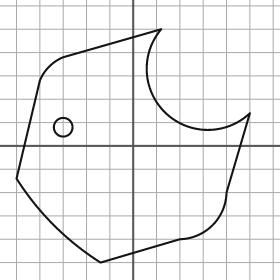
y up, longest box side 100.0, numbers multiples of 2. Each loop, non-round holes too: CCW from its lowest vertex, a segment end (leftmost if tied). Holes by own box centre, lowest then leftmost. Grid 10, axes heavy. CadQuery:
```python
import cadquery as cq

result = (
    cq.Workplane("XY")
    .moveTo(-14.0, -50.0)
    .lineTo(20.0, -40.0)
    .threePointArc((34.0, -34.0), (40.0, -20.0))
    .lineTo(50.0, 14.0)
    .threePointArc((14.0, 14.0), (12.0, 50.0))
    .lineTo(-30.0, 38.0)
    .threePointArc((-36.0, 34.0), (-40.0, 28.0))
    .lineTo(-50.0, -14.0)
    .threePointArc((-34.0, -34.0), (-14.0, -50.0))
    .close()
    .moveTo(-30.0, 8.0)
    .circle(4.0)
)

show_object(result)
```